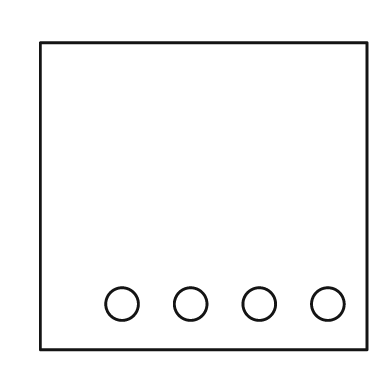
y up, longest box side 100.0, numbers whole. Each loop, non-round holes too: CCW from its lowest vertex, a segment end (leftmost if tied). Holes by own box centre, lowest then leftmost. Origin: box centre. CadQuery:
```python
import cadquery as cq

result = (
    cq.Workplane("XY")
    .moveTo(-50.0, -47.0)
    .lineTo(50.0, -47.0)
    .lineTo(50.0, 47.0)
    .lineTo(-50.0, 47.0)
    .close()
    .moveTo(-25.0, -33.0)
    .circle(5.0)
    .moveTo(-4.0, -33.0)
    .circle(5.0)
    .moveTo(17.0, -33.0)
    .circle(5.0)
    .moveTo(38.0, -33.0)
    .circle(5.0)
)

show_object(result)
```